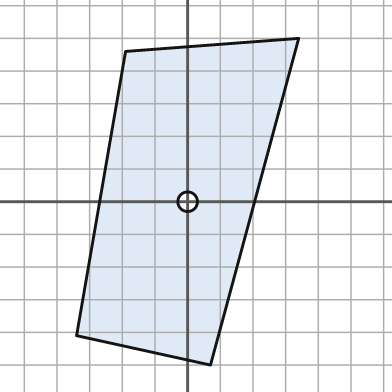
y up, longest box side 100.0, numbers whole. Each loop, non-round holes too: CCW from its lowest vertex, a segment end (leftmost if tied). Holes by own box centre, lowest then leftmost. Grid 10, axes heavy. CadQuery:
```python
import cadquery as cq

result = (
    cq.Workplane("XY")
    .moveTo(7.0, -50.0)
    .lineTo(34.0, 50.0)
    .lineTo(-19.0, 46.0)
    .lineTo(-34.0, -41.0)
    .close()
    .moveTo(0.0, 0.0)
    .circle(3.0)
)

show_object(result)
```